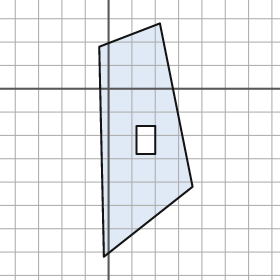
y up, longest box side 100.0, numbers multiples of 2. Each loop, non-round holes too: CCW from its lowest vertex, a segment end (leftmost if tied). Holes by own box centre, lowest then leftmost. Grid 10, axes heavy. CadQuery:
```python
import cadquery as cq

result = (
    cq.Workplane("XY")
    .moveTo(-2.0, -72.0)
    .lineTo(36.0, -42.0)
    .lineTo(22.0, 28.0)
    .lineTo(-4.0, 18.0)
    .close()
    .moveTo(12.0, -28.0)
    .lineTo(20.0, -28.0)
    .lineTo(20.0, -16.0)
    .lineTo(12.0, -16.0)
    .close()
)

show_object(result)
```